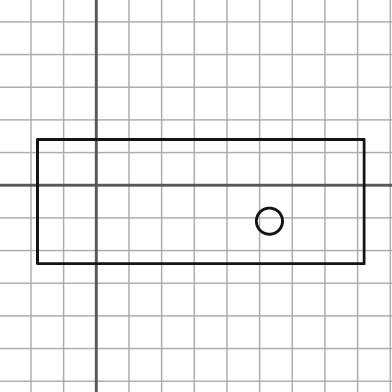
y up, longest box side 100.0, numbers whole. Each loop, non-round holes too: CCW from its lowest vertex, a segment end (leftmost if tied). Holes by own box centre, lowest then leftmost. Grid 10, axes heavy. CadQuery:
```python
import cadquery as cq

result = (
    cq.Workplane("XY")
    .moveTo(-18.0, -24.0)
    .lineTo(82.0, -24.0)
    .lineTo(82.0, 14.0)
    .lineTo(-18.0, 14.0)
    .close()
    .moveTo(53.0, -11.0)
    .circle(4.0)
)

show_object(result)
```